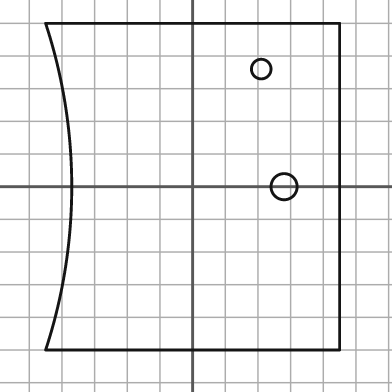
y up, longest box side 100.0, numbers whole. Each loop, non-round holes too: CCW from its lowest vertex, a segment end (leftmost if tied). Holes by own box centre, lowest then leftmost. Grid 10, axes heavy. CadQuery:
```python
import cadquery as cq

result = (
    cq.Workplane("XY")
    .moveTo(-45.0, -50.0)
    .lineTo(45.0, -50.0)
    .lineTo(45.0, 50.0)
    .lineTo(-45.0, 50.0)
    .threePointArc((-37.0, 0.0), (-45.0, -50.0))
    .close()
    .moveTo(28.0, 0.0)
    .circle(4.0)
    .moveTo(21.0, 36.0)
    .circle(3.0)
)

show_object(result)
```